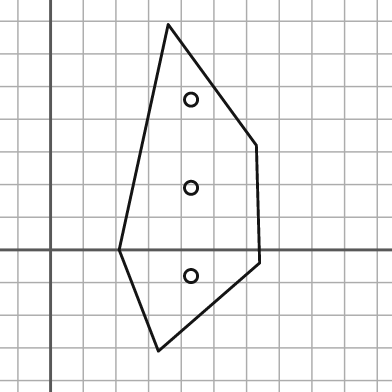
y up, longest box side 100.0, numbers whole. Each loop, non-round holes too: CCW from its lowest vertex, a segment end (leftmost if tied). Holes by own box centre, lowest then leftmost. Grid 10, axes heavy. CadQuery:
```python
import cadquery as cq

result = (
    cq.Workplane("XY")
    .moveTo(33.0, -31.0)
    .lineTo(64.0, -4.0)
    .lineTo(63.0, 32.0)
    .lineTo(36.0, 69.0)
    .lineTo(21.0, 0.0)
    .close()
    .moveTo(43.0, -8.0)
    .circle(2.0)
    .moveTo(43.0, 19.0)
    .circle(2.0)
    .moveTo(43.0, 46.0)
    .circle(2.0)
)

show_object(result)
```